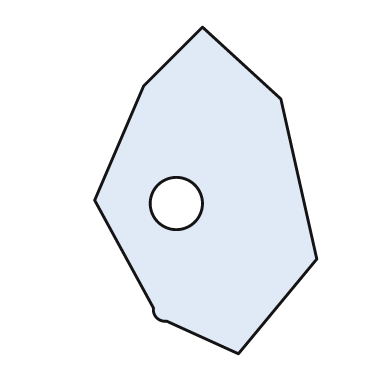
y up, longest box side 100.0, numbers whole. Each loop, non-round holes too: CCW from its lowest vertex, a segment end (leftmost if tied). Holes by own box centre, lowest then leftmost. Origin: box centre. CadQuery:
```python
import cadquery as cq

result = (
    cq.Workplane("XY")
    .moveTo(10.0, -50.0)
    .lineTo(34.0, -21.0)
    .lineTo(23.0, 28.0)
    .lineTo(-1.0, 50.0)
    .lineTo(-19.0, 32.0)
    .lineTo(-34.0, -3.0)
    .lineTo(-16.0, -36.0)
    .threePointArc((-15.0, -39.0), (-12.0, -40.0))
    .close()
    .moveTo(-9.0, -4.0)
    .circle(8.0)
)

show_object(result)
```